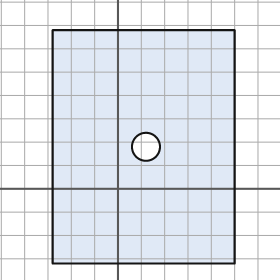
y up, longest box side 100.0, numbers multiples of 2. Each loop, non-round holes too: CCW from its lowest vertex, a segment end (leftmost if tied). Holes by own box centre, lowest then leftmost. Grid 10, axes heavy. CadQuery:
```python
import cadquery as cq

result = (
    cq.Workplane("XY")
    .moveTo(-28.0, -32.0)
    .lineTo(50.0, -32.0)
    .lineTo(50.0, 68.0)
    .lineTo(-28.0, 68.0)
    .close()
    .moveTo(12.0, 18.0)
    .circle(6.0)
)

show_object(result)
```